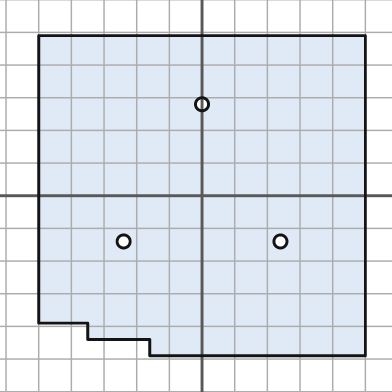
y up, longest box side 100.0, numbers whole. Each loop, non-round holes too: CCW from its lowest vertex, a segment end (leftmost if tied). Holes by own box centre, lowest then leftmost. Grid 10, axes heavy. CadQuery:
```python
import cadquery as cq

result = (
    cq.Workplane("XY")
    .moveTo(-16.0, -49.0)
    .lineTo(50.0, -49.0)
    .lineTo(50.0, 49.0)
    .lineTo(-50.0, 49.0)
    .lineTo(-50.0, -39.0)
    .lineTo(-35.0, -39.0)
    .lineTo(-35.0, -44.0)
    .lineTo(-16.0, -44.0)
    .close()
    .moveTo(-24.0, -14.0)
    .circle(2.0)
    .moveTo(24.0, -14.0)
    .circle(2.0)
    .moveTo(0.0, 28.0)
    .circle(2.0)
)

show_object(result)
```